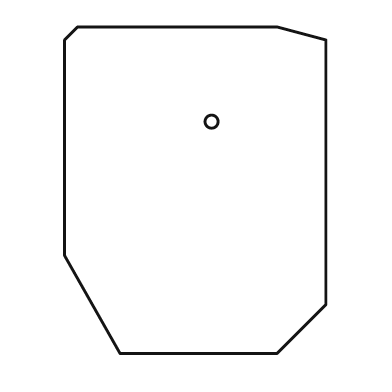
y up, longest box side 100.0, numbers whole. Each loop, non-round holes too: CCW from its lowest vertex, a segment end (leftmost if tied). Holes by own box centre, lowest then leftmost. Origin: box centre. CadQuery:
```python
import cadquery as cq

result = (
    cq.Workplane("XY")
    .moveTo(-23.0, -50.0)
    .lineTo(25.0, -50.0)
    .lineTo(40.0, -35.0)
    .lineTo(40.0, 46.0)
    .lineTo(25.0, 50.0)
    .lineTo(-36.0, 50.0)
    .lineTo(-40.0, 46.0)
    .lineTo(-40.0, -20.0)
    .close()
    .moveTo(5.0, 21.0)
    .circle(2.0)
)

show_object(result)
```